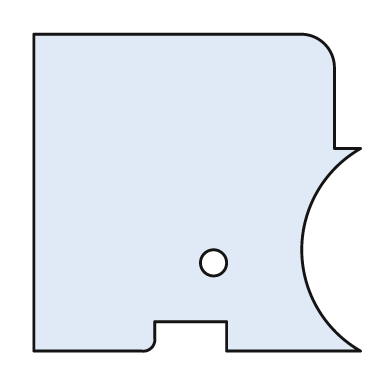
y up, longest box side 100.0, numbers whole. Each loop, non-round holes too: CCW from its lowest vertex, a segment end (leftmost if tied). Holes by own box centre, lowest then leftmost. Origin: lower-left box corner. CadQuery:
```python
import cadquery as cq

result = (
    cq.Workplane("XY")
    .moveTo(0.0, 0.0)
    .lineTo(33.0, 0.0)
    .threePointArc((36.0, 1.0), (37.0, 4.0))
    .lineTo(37.0, 9.0)
    .lineTo(59.0, 9.0)
    .lineTo(59.0, 0.0)
    .lineTo(100.0, 0.0)
    .threePointArc((82.0, 31.0), (100.0, 62.0))
    .lineTo(92.0, 62.0)
    .lineTo(92.0, 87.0)
    .threePointArc((89.0, 94.0), (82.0, 97.0))
    .lineTo(0.0, 97.0)
    .close()
    .moveTo(55.0, 27.0)
    .circle(4.0)
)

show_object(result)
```